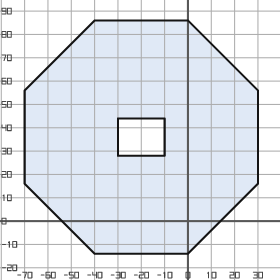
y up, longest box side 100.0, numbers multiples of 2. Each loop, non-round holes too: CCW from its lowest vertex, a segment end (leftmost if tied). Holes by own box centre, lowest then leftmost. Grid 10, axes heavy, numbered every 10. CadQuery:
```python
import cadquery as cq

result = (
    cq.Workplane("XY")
    .moveTo(-40.0, -14.0)
    .lineTo(0.0, -14.0)
    .lineTo(30.0, 16.0)
    .lineTo(30.0, 56.0)
    .lineTo(0.0, 86.0)
    .lineTo(-40.0, 86.0)
    .lineTo(-70.0, 56.0)
    .lineTo(-70.0, 16.0)
    .close()
    .moveTo(-30.0, 28.0)
    .lineTo(-10.0, 28.0)
    .lineTo(-10.0, 44.0)
    .lineTo(-30.0, 44.0)
    .close()
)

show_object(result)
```